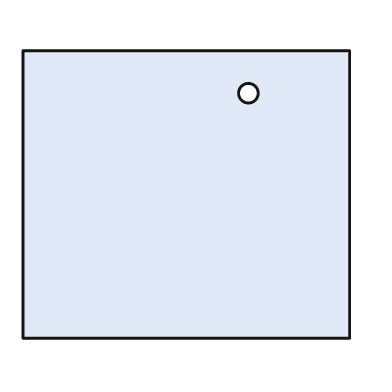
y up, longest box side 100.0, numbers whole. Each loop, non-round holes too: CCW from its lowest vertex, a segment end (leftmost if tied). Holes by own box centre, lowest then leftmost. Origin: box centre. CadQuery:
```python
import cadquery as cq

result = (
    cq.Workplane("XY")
    .moveTo(-50.0, -44.0)
    .lineTo(50.0, -44.0)
    .lineTo(50.0, 44.0)
    .lineTo(-50.0, 44.0)
    .close()
    .moveTo(19.0, 31.0)
    .circle(3.0)
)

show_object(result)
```